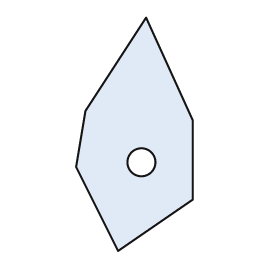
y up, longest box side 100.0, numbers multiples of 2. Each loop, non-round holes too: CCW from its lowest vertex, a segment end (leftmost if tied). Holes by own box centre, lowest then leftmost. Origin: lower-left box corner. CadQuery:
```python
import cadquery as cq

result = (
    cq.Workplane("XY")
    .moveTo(18.0, 0.0)
    .lineTo(50.0, 22.0)
    .lineTo(50.0, 56.0)
    .lineTo(30.0, 100.0)
    .lineTo(4.0, 60.0)
    .lineTo(0.0, 36.0)
    .close()
    .moveTo(28.0, 38.0)
    .circle(6.0)
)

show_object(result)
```